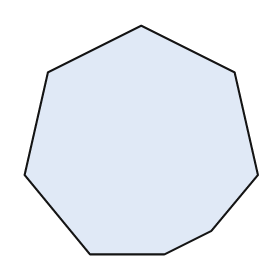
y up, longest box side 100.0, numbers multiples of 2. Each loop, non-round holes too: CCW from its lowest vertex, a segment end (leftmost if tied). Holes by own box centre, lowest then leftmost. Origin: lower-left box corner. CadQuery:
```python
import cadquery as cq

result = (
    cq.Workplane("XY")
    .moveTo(28.0, 0.0)
    .lineTo(60.0, 0.0)
    .lineTo(80.0, 10.0)
    .lineTo(100.0, 34.0)
    .lineTo(90.0, 78.0)
    .lineTo(50.0, 98.0)
    .lineTo(10.0, 78.0)
    .lineTo(0.0, 34.0)
    .close()
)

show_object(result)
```